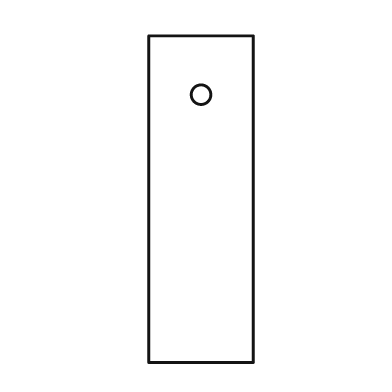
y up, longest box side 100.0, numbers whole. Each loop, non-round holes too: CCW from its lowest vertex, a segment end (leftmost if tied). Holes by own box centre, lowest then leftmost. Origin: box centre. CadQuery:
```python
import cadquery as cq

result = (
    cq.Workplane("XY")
    .moveTo(-16.0, -50.0)
    .lineTo(16.0, -50.0)
    .lineTo(16.0, 50.0)
    .lineTo(-16.0, 50.0)
    .close()
    .moveTo(0.0, 32.0)
    .circle(3.0)
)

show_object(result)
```